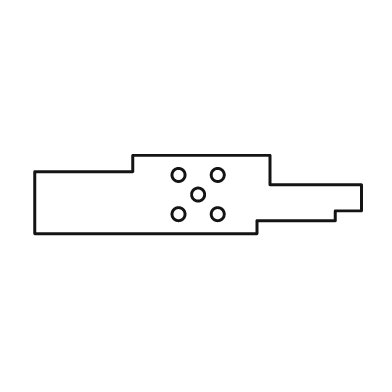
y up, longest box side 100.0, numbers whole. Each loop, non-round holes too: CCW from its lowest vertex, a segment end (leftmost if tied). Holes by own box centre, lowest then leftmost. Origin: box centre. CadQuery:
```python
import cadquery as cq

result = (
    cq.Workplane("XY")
    .moveTo(-50.0, -12.0)
    .lineTo(18.0, -12.0)
    .lineTo(18.0, -8.0)
    .lineTo(42.0, -8.0)
    .lineTo(42.0, -5.0)
    .lineTo(50.0, -5.0)
    .lineTo(50.0, 3.0)
    .lineTo(22.0, 3.0)
    .lineTo(22.0, 12.0)
    .lineTo(-20.0, 12.0)
    .lineTo(-20.0, 7.0)
    .lineTo(-50.0, 7.0)
    .close()
    .moveTo(-6.0, -6.0)
    .circle(2.0)
    .moveTo(6.0, -6.0)
    .circle(2.0)
    .moveTo(0.0, 0.0)
    .circle(2.0)
    .moveTo(-6.0, 6.0)
    .circle(2.0)
    .moveTo(6.0, 6.0)
    .circle(2.0)
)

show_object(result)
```